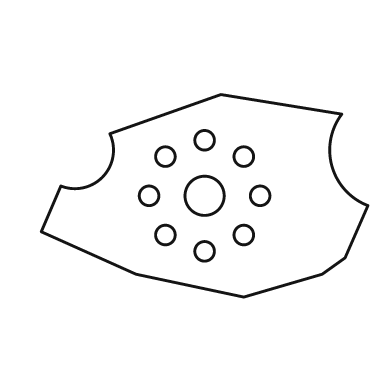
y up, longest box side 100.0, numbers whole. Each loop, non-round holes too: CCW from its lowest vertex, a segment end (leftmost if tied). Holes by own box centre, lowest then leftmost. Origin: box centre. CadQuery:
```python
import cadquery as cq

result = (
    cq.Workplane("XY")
    .moveTo(12.0, -31.0)
    .lineTo(36.0, -24.0)
    .lineTo(43.0, -19.0)
    .lineTo(50.0, -3.0)
    .threePointArc((39.0, 9.0), (42.0, 25.0))
    .lineTo(5.0, 31.0)
    .lineTo(-29.0, 19.0)
    .threePointArc((-31.0, 6.0), (-44.0, 3.0))
    .lineTo(-50.0, -11.0)
    .lineTo(-21.0, -24.0)
    .close()
    .moveTo(0.0, -17.0)
    .circle(3.0)
    .moveTo(-12.0, -12.0)
    .circle(3.0)
    .moveTo(12.0, -12.0)
    .circle(3.0)
    .moveTo(-17.0, 0.0)
    .circle(3.0)
    .moveTo(0.0, 0.0)
    .circle(6.0)
    .moveTo(17.0, 0.0)
    .circle(3.0)
    .moveTo(-12.0, 12.0)
    .circle(3.0)
    .moveTo(12.0, 12.0)
    .circle(3.0)
    .moveTo(0.0, 17.0)
    .circle(3.0)
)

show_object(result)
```